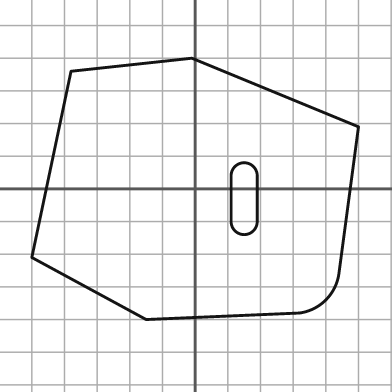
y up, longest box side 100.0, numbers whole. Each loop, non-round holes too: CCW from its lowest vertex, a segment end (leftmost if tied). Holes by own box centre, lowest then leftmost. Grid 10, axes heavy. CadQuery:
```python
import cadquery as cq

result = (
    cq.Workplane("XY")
    .moveTo(-15.0, -40.0)
    .lineTo(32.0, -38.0)
    .threePointArc((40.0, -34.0), (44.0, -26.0))
    .lineTo(50.0, 19.0)
    .lineTo(-1.0, 40.0)
    .lineTo(-38.0, 36.0)
    .lineTo(-50.0, -21.0)
    .close()
    .moveTo(11.0, -10.0)
    .threePointArc((15.0, -14.0), (19.0, -10.0))
    .lineTo(19.0, 4.0)
    .threePointArc((15.0, 8.0), (11.0, 4.0))
    .close()
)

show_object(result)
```